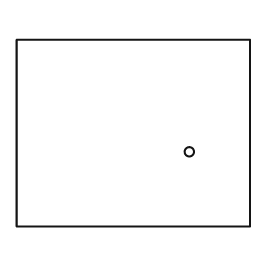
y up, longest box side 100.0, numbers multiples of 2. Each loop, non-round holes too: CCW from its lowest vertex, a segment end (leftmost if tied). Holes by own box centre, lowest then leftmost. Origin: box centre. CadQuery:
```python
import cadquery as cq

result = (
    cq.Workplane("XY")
    .moveTo(-50.0, -40.0)
    .lineTo(50.0, -40.0)
    .lineTo(50.0, 40.0)
    .lineTo(-50.0, 40.0)
    .close()
    .moveTo(24.0, -8.0)
    .circle(2.0)
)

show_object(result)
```